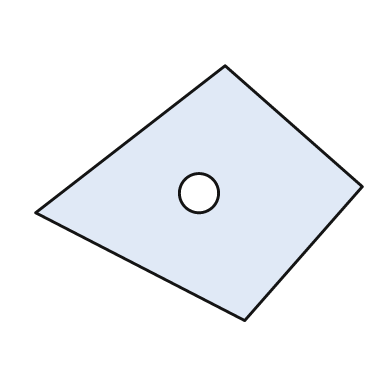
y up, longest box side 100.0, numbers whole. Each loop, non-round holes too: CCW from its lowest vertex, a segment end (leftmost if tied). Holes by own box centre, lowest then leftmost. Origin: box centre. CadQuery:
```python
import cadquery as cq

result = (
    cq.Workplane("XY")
    .moveTo(14.0, -39.0)
    .lineTo(50.0, 2.0)
    .lineTo(8.0, 39.0)
    .lineTo(-50.0, -6.0)
    .close()
    .moveTo(0.0, 0.0)
    .circle(6.0)
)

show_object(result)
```